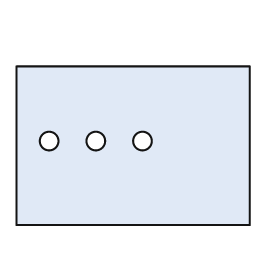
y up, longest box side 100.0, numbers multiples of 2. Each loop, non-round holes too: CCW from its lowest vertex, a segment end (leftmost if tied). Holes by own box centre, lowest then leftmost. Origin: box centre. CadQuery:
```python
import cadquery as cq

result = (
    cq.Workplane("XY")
    .moveTo(-50.0, -34.0)
    .lineTo(50.0, -34.0)
    .lineTo(50.0, 34.0)
    .lineTo(-50.0, 34.0)
    .close()
    .moveTo(-36.0, 2.0)
    .circle(4.0)
    .moveTo(-16.0, 2.0)
    .circle(4.0)
    .moveTo(4.0, 2.0)
    .circle(4.0)
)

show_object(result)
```